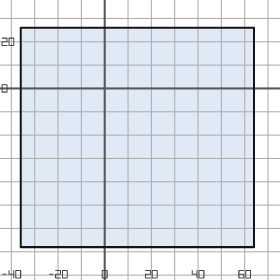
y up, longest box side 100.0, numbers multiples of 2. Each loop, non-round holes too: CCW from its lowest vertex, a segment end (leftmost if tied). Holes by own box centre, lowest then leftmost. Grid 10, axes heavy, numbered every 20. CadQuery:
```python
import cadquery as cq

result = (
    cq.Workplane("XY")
    .moveTo(-36.0, -68.0)
    .lineTo(64.0, -68.0)
    .lineTo(64.0, 26.0)
    .lineTo(-36.0, 26.0)
    .close()
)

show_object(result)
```